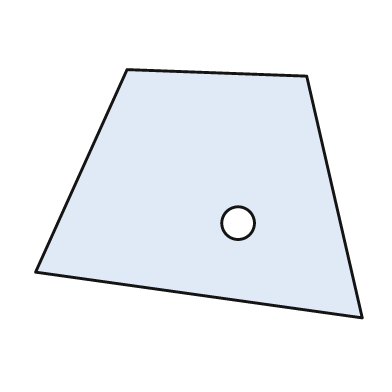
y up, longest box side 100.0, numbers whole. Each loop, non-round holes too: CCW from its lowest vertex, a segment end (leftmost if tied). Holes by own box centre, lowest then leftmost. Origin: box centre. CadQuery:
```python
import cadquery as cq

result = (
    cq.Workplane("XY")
    .moveTo(50.0, -38.0)
    .lineTo(33.0, 36.0)
    .lineTo(-22.0, 38.0)
    .lineTo(-50.0, -24.0)
    .close()
    .moveTo(12.0, -9.0)
    .circle(5.0)
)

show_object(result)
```